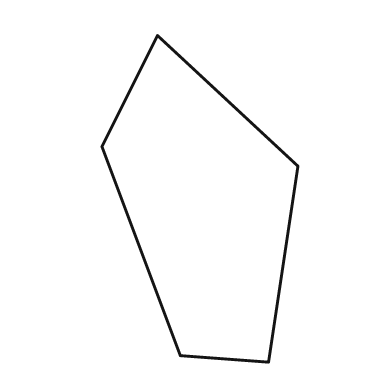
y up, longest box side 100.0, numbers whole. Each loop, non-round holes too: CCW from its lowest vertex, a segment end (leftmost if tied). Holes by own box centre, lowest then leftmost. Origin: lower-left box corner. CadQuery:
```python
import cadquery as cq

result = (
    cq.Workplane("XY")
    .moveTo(51.0, 0.0)
    .lineTo(60.0, 60.0)
    .lineTo(17.0, 100.0)
    .lineTo(0.0, 66.0)
    .lineTo(24.0, 2.0)
    .close()
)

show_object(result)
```